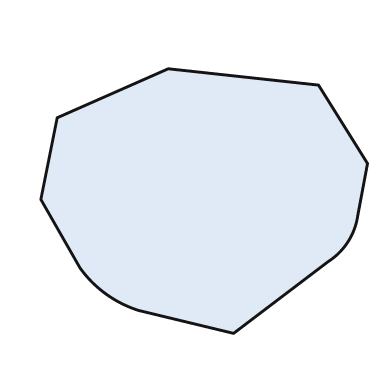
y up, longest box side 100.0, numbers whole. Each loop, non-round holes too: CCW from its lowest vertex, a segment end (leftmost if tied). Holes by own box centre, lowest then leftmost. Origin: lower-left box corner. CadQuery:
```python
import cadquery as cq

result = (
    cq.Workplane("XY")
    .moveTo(59.0, 0.0)
    .lineTo(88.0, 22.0)
    .threePointArc((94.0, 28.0), (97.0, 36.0))
    .lineTo(100.0, 52.0)
    .lineTo(85.0, 76.0)
    .lineTo(39.0, 81.0)
    .lineTo(5.0, 66.0)
    .lineTo(0.0, 41.0)
    .lineTo(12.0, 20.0)
    .threePointArc((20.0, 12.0), (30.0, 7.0))
    .close()
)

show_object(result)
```